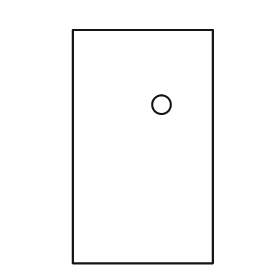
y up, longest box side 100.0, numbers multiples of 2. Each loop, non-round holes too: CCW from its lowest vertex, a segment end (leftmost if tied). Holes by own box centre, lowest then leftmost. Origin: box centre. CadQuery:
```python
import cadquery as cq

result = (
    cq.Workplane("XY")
    .moveTo(-30.0, -50.0)
    .lineTo(30.0, -50.0)
    .lineTo(30.0, 50.0)
    .lineTo(-30.0, 50.0)
    .close()
    .moveTo(8.0, 18.0)
    .circle(4.0)
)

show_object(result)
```